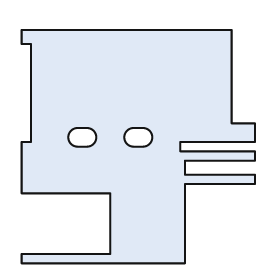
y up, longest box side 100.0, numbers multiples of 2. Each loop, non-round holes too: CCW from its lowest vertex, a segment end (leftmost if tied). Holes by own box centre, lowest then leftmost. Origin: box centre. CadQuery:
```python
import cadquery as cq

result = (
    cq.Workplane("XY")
    .moveTo(-50.0, -50.0)
    .lineTo(20.0, -50.0)
    .lineTo(20.0, -16.0)
    .lineTo(50.0, -16.0)
    .lineTo(50.0, -12.0)
    .lineTo(20.0, -12.0)
    .lineTo(20.0, -6.0)
    .lineTo(50.0, -6.0)
    .lineTo(50.0, -2.0)
    .lineTo(18.0, -2.0)
    .lineTo(18.0, 2.0)
    .lineTo(50.0, 2.0)
    .lineTo(50.0, 10.0)
    .lineTo(40.0, 10.0)
    .lineTo(40.0, 50.0)
    .lineTo(-50.0, 50.0)
    .lineTo(-50.0, 44.0)
    .lineTo(-46.0, 44.0)
    .lineTo(-46.0, 2.0)
    .lineTo(-50.0, 2.0)
    .lineTo(-50.0, -20.0)
    .lineTo(-12.0, -20.0)
    .lineTo(-12.0, -46.0)
    .lineTo(-50.0, -46.0)
    .close()
    .moveTo(-26.0, 0.0)
    .lineTo(-22.0, 0.0)
    .threePointArc((-18.0, 4.0), (-22.0, 8.0))
    .lineTo(-26.0, 8.0)
    .threePointArc((-30.0, 4.0), (-26.0, 0.0))
    .close()
    .moveTo(-2.0, 0.0)
    .lineTo(2.0, 0.0)
    .threePointArc((6.0, 4.0), (2.0, 8.0))
    .lineTo(-2.0, 8.0)
    .threePointArc((-6.0, 4.0), (-2.0, 0.0))
    .close()
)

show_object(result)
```